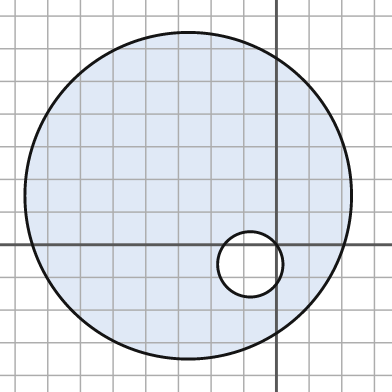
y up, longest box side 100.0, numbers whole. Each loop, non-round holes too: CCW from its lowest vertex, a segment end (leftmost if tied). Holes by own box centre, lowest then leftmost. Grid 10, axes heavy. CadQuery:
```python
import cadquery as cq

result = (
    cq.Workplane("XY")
    .moveTo(-27.0, 15.0)
    .circle(50.0)
    .moveTo(-8.0, -6.0)
    .circle(10.0)
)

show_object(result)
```